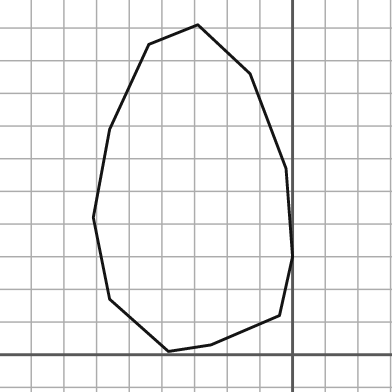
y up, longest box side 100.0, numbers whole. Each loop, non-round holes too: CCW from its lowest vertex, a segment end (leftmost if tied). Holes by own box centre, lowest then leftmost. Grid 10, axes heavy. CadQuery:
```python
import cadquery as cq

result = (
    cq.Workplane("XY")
    .moveTo(-38.0, 1.0)
    .lineTo(-25.0, 3.0)
    .lineTo(-4.0, 12.0)
    .lineTo(0.0, 30.0)
    .lineTo(-2.0, 57.0)
    .lineTo(-13.0, 86.0)
    .lineTo(-29.0, 101.0)
    .lineTo(-44.0, 95.0)
    .lineTo(-56.0, 69.0)
    .lineTo(-61.0, 42.0)
    .lineTo(-56.0, 17.0)
    .close()
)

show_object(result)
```